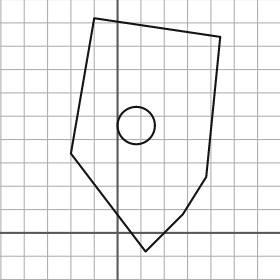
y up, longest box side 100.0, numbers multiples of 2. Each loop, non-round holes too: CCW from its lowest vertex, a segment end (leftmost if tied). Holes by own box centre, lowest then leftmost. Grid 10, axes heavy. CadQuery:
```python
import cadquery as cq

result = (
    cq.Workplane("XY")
    .moveTo(12.0, -8.0)
    .lineTo(28.0, 8.0)
    .lineTo(38.0, 24.0)
    .lineTo(44.0, 84.0)
    .lineTo(-10.0, 92.0)
    .lineTo(-20.0, 34.0)
    .close()
    .moveTo(8.0, 46.0)
    .circle(8.0)
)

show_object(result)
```